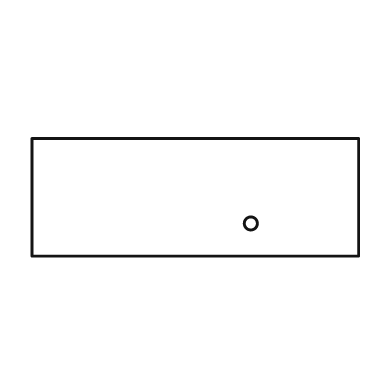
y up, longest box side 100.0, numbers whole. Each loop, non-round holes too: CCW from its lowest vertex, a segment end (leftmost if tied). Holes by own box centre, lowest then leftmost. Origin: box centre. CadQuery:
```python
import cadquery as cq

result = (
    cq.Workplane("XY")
    .moveTo(-50.0, -18.0)
    .lineTo(50.0, -18.0)
    .lineTo(50.0, 18.0)
    .lineTo(-50.0, 18.0)
    .close()
    .moveTo(17.0, -8.0)
    .circle(2.0)
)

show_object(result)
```